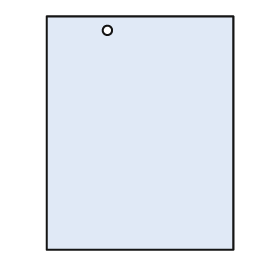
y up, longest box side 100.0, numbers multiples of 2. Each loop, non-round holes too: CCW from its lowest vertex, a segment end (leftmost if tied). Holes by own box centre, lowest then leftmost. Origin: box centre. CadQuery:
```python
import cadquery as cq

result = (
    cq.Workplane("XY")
    .moveTo(-40.0, -50.0)
    .lineTo(40.0, -50.0)
    .lineTo(40.0, 50.0)
    .lineTo(-40.0, 50.0)
    .close()
    .moveTo(-14.0, 44.0)
    .circle(2.0)
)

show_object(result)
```